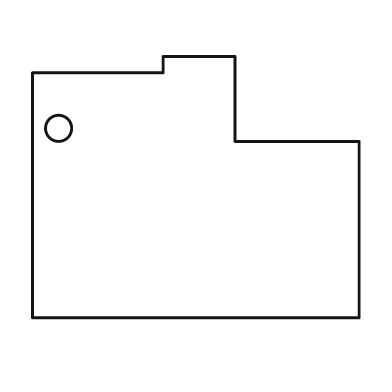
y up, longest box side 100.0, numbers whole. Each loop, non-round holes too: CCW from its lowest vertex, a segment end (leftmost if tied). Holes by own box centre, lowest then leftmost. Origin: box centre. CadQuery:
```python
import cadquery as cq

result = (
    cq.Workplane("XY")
    .moveTo(-50.0, -40.0)
    .lineTo(50.0, -40.0)
    .lineTo(50.0, 14.0)
    .lineTo(12.0, 14.0)
    .lineTo(12.0, 40.0)
    .lineTo(-10.0, 40.0)
    .lineTo(-10.0, 35.0)
    .lineTo(-50.0, 35.0)
    .close()
    .moveTo(-42.0, 18.0)
    .circle(4.0)
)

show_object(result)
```